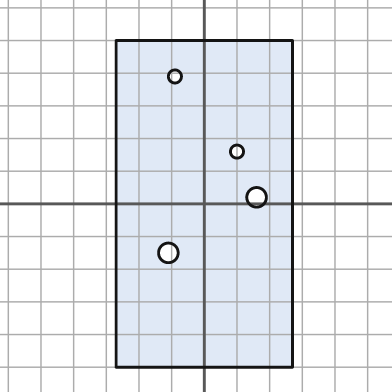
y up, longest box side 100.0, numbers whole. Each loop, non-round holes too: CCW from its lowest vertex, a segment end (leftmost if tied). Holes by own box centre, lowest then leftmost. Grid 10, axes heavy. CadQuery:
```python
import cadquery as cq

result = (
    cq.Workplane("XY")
    .moveTo(-27.0, -50.0)
    .lineTo(27.0, -50.0)
    .lineTo(27.0, 50.0)
    .lineTo(-27.0, 50.0)
    .close()
    .moveTo(-11.0, -15.0)
    .circle(3.0)
    .moveTo(16.0, 2.0)
    .circle(3.0)
    .moveTo(10.0, 16.0)
    .circle(2.0)
    .moveTo(-9.0, 39.0)
    .circle(2.0)
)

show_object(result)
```